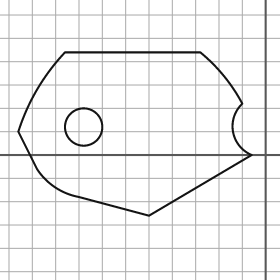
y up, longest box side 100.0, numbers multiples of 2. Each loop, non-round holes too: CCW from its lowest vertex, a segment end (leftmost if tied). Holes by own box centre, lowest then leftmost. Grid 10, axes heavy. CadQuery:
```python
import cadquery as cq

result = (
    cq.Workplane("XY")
    .moveTo(-50.0, -26.0)
    .lineTo(-6.0, 0.0)
    .threePointArc((-14.0, 10.0), (-10.0, 22.0))
    .threePointArc((-18.0, 34.0), (-28.0, 44.0))
    .lineTo(-86.0, 44.0)
    .threePointArc((-98.0, 28.0), (-106.0, 10.0))
    .lineTo(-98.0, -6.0)
    .threePointArc((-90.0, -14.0), (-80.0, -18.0))
    .close()
    .moveTo(-78.0, 12.0)
    .circle(8.0)
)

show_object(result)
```